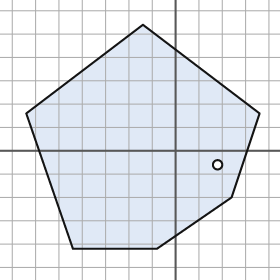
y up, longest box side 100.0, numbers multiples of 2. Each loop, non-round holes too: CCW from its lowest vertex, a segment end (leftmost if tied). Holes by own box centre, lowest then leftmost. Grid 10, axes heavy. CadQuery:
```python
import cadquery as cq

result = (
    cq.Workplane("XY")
    .moveTo(-44.0, -42.0)
    .lineTo(-8.0, -42.0)
    .lineTo(24.0, -20.0)
    .lineTo(36.0, 16.0)
    .lineTo(-14.0, 54.0)
    .lineTo(-64.0, 16.0)
    .close()
    .moveTo(18.0, -6.0)
    .circle(2.0)
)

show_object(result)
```